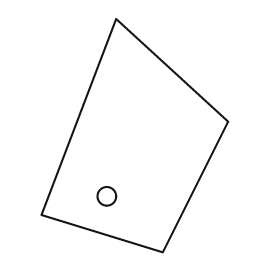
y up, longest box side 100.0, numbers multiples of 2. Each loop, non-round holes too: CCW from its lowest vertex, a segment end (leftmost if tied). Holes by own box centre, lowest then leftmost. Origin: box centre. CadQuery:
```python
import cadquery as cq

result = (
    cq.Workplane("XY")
    .moveTo(12.0, -50.0)
    .lineTo(40.0, 6.0)
    .lineTo(-8.0, 50.0)
    .lineTo(-40.0, -34.0)
    .close()
    .moveTo(-12.0, -26.0)
    .circle(4.0)
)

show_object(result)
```